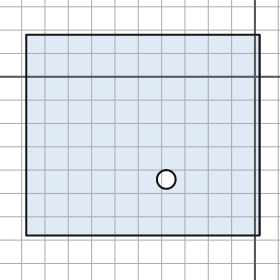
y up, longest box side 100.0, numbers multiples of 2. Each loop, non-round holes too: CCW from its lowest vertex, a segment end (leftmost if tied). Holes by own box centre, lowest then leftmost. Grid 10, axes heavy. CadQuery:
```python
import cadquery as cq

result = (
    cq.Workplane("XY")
    .moveTo(-98.0, -68.0)
    .lineTo(2.0, -68.0)
    .lineTo(2.0, 18.0)
    .lineTo(-98.0, 18.0)
    .close()
    .moveTo(-38.0, -44.0)
    .circle(4.0)
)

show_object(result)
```